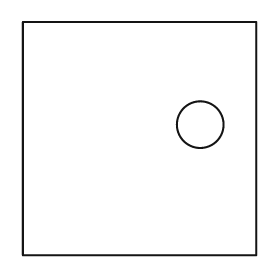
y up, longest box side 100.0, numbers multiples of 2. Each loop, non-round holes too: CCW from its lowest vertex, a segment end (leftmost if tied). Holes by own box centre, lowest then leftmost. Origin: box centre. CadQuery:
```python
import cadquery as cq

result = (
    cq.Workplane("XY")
    .moveTo(-50.0, -50.0)
    .lineTo(50.0, -50.0)
    .lineTo(50.0, 50.0)
    .lineTo(-50.0, 50.0)
    .close()
    .moveTo(26.0, 6.0)
    .circle(10.0)
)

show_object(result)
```